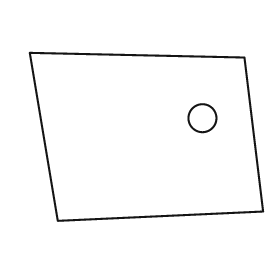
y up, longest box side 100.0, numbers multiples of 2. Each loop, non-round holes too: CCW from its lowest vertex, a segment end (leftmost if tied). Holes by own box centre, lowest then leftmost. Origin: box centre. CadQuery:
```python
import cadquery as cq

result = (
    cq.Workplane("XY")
    .moveTo(-38.0, -36.0)
    .lineTo(50.0, -32.0)
    .lineTo(42.0, 34.0)
    .lineTo(-50.0, 36.0)
    .close()
    .moveTo(24.0, 8.0)
    .circle(6.0)
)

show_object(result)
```